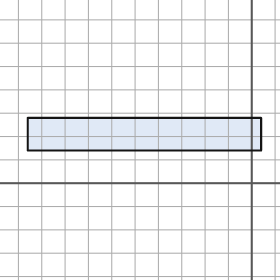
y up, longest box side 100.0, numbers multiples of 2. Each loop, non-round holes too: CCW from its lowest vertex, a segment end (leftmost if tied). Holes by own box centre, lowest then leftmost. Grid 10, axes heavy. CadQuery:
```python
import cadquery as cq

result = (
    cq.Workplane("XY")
    .moveTo(-96.0, 14.0)
    .lineTo(4.0, 14.0)
    .lineTo(4.0, 28.0)
    .lineTo(-96.0, 28.0)
    .close()
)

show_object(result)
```